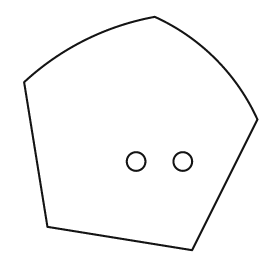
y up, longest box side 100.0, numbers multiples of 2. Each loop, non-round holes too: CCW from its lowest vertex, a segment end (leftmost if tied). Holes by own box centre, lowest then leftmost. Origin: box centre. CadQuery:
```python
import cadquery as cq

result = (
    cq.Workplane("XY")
    .moveTo(22.0, -50.0)
    .lineTo(50.0, 6.0)
    .threePointArc((32.0, 32.0), (6.0, 50.0))
    .threePointArc((-24.0, 40.0), (-50.0, 22.0))
    .lineTo(-40.0, -40.0)
    .close()
    .moveTo(-2.0, -12.0)
    .circle(4.0)
    .moveTo(18.0, -12.0)
    .circle(4.0)
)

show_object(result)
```